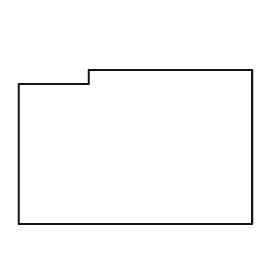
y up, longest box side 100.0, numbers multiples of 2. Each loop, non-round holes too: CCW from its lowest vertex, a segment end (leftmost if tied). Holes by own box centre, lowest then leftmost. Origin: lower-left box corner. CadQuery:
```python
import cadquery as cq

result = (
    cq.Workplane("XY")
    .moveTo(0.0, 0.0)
    .lineTo(100.0, 0.0)
    .lineTo(100.0, 66.0)
    .lineTo(30.0, 66.0)
    .lineTo(30.0, 60.0)
    .lineTo(0.0, 60.0)
    .close()
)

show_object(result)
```